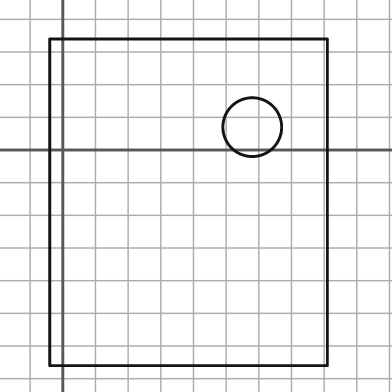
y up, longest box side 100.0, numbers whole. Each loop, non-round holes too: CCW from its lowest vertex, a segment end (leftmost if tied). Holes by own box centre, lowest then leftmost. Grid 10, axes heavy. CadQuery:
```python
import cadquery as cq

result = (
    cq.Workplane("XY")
    .moveTo(-4.0, -66.0)
    .lineTo(81.0, -66.0)
    .lineTo(81.0, 34.0)
    .lineTo(-4.0, 34.0)
    .close()
    .moveTo(58.0, 7.0)
    .circle(9.0)
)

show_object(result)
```